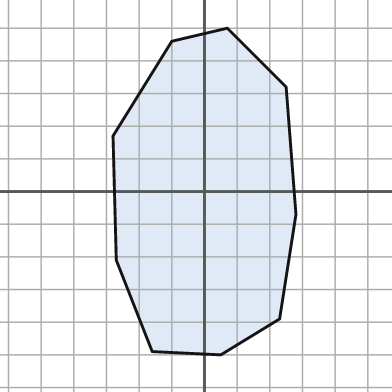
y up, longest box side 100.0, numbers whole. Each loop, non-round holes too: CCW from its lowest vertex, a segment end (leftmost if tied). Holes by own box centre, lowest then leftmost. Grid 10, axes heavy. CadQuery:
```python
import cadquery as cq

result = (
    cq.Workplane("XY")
    .moveTo(5.0, -50.0)
    .lineTo(23.0, -39.0)
    .lineTo(28.0, -7.0)
    .lineTo(25.0, 32.0)
    .lineTo(7.0, 50.0)
    .lineTo(-10.0, 46.0)
    .lineTo(-28.0, 17.0)
    .lineTo(-27.0, -21.0)
    .lineTo(-16.0, -49.0)
    .close()
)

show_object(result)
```